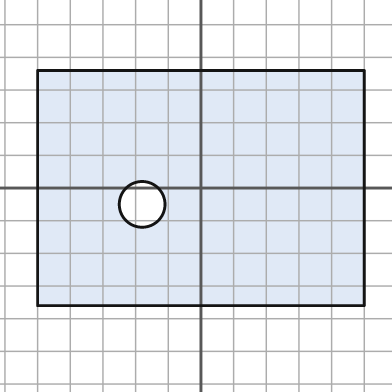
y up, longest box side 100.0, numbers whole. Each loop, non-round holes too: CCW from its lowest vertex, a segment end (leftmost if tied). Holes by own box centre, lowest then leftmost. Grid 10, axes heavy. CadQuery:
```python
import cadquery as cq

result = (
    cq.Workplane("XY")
    .moveTo(-50.0, -36.0)
    .lineTo(50.0, -36.0)
    .lineTo(50.0, 36.0)
    .lineTo(-50.0, 36.0)
    .close()
    .moveTo(-18.0, -5.0)
    .circle(7.0)
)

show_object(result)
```